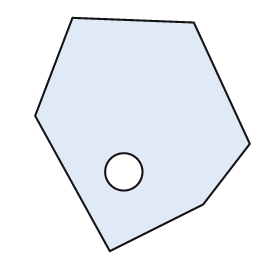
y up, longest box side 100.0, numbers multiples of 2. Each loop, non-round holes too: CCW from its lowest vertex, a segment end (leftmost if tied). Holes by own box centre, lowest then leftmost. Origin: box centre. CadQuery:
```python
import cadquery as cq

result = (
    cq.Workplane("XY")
    .moveTo(-14.0, -50.0)
    .lineTo(26.0, -30.0)
    .lineTo(46.0, -4.0)
    .lineTo(22.0, 48.0)
    .lineTo(-30.0, 50.0)
    .lineTo(-46.0, 8.0)
    .close()
    .moveTo(-8.0, -16.0)
    .circle(8.0)
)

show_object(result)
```